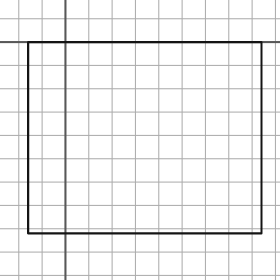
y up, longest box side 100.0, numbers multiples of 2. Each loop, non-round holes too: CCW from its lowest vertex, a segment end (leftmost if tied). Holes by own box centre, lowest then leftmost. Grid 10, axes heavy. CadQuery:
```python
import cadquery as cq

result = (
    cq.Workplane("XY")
    .moveTo(-16.0, -82.0)
    .lineTo(84.0, -82.0)
    .lineTo(84.0, 0.0)
    .lineTo(-16.0, 0.0)
    .close()
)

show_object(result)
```